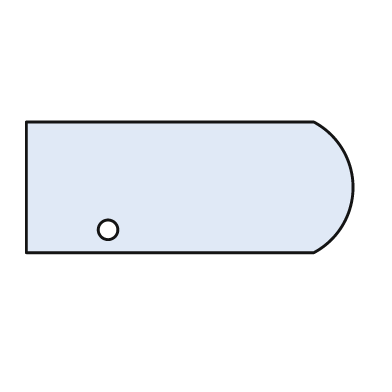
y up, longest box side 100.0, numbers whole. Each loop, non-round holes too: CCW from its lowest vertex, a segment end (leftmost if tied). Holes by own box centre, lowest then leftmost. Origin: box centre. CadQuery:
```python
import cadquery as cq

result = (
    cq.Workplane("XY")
    .moveTo(-50.0, -20.0)
    .lineTo(38.0, -20.0)
    .threePointArc((50.0, 0.0), (38.0, 20.0))
    .lineTo(-50.0, 20.0)
    .close()
    .moveTo(-25.0, -13.0)
    .circle(3.0)
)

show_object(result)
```